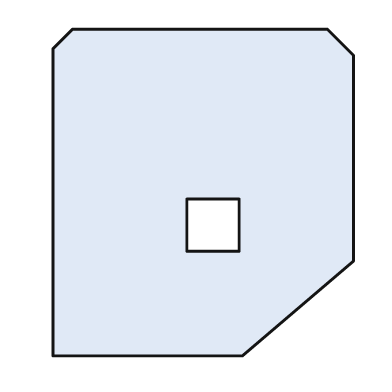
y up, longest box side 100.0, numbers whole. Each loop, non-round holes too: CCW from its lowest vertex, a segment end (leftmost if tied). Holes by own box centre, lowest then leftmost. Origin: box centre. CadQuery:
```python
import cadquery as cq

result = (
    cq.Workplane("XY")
    .moveTo(-46.0, -50.0)
    .lineTo(12.0, -50.0)
    .lineTo(46.0, -21.0)
    .lineTo(46.0, 42.0)
    .lineTo(38.0, 50.0)
    .lineTo(-40.0, 50.0)
    .lineTo(-46.0, 44.0)
    .close()
    .moveTo(-5.0, -18.0)
    .lineTo(11.0, -18.0)
    .lineTo(11.0, -2.0)
    .lineTo(-5.0, -2.0)
    .close()
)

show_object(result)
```